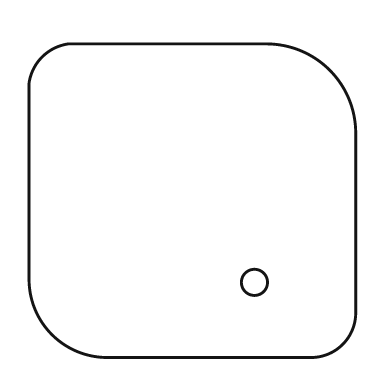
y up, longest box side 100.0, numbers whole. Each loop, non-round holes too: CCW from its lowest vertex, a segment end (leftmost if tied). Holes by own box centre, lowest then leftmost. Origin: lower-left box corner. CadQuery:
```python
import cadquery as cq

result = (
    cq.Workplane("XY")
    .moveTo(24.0, 0.0)
    .lineTo(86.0, 0.0)
    .threePointArc((96.0, 4.0), (100.0, 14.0))
    .lineTo(100.0, 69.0)
    .threePointArc((92.0, 88.0), (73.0, 96.0))
    .lineTo(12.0, 96.0)
    .threePointArc((4.0, 92.0), (0.0, 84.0))
    .lineTo(0.0, 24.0)
    .threePointArc((7.0, 7.0), (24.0, 0.0))
    .close()
    .moveTo(69.0, 23.0)
    .circle(4.0)
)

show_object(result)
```